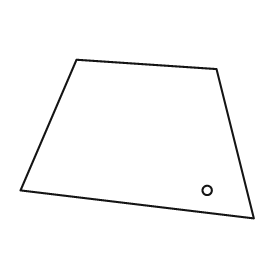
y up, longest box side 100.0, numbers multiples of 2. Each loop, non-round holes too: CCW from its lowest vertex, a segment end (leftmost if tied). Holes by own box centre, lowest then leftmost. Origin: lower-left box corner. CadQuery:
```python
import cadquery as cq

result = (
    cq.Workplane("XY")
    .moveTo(100.0, 0.0)
    .lineTo(84.0, 64.0)
    .lineTo(24.0, 68.0)
    .lineTo(0.0, 12.0)
    .close()
    .moveTo(80.0, 12.0)
    .circle(2.0)
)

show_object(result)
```